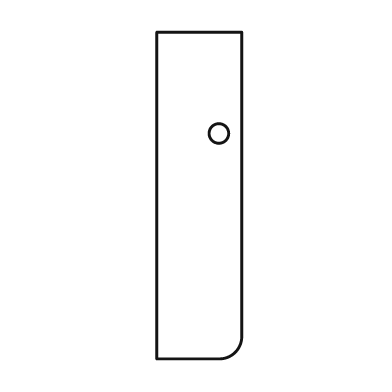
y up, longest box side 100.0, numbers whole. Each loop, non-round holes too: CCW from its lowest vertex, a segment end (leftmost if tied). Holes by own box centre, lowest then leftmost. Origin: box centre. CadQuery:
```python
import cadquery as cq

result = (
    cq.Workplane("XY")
    .moveTo(-13.0, -50.0)
    .lineTo(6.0, -50.0)
    .threePointArc((11.0, -48.0), (13.0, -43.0))
    .lineTo(13.0, 50.0)
    .lineTo(-13.0, 50.0)
    .close()
    .moveTo(6.0, 19.0)
    .circle(3.0)
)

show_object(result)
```